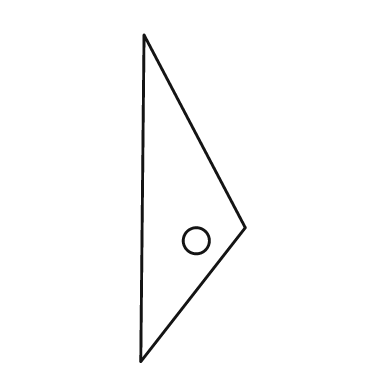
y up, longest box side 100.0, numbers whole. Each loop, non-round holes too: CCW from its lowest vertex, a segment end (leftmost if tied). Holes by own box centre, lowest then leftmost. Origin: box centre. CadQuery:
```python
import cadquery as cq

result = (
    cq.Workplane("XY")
    .moveTo(-16.0, -50.0)
    .lineTo(16.0, -9.0)
    .lineTo(-15.0, 50.0)
    .close()
    .moveTo(1.0, -13.0)
    .circle(4.0)
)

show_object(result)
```